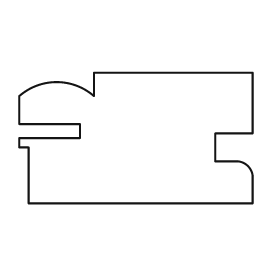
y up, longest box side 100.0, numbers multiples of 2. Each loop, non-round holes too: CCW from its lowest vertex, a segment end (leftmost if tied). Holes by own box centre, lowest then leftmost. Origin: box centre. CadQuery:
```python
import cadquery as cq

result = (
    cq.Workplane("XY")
    .moveTo(-46.0, -28.0)
    .lineTo(50.0, -28.0)
    .lineTo(50.0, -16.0)
    .threePointArc((48.0, -12.0), (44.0, -10.0))
    .lineTo(34.0, -10.0)
    .lineTo(34.0, 2.0)
    .lineTo(50.0, 2.0)
    .lineTo(50.0, 28.0)
    .lineTo(-18.0, 28.0)
    .lineTo(-18.0, 18.0)
    .threePointArc((-34.0, 24.0), (-50.0, 18.0))
    .lineTo(-50.0, 6.0)
    .lineTo(-24.0, 6.0)
    .lineTo(-24.0, 0.0)
    .lineTo(-50.0, 0.0)
    .lineTo(-50.0, -4.0)
    .lineTo(-46.0, -4.0)
    .close()
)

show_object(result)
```